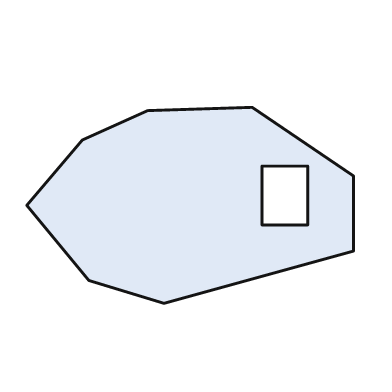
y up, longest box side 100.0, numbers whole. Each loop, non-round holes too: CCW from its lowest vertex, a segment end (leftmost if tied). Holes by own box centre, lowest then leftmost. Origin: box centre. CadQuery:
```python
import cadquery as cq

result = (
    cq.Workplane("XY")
    .moveTo(-8.0, -30.0)
    .lineTo(50.0, -14.0)
    .lineTo(50.0, 9.0)
    .lineTo(19.0, 30.0)
    .lineTo(-13.0, 29.0)
    .lineTo(-33.0, 20.0)
    .lineTo(-50.0, 0.0)
    .lineTo(-31.0, -23.0)
    .close()
    .moveTo(22.0, -6.0)
    .lineTo(36.0, -6.0)
    .lineTo(36.0, 12.0)
    .lineTo(22.0, 12.0)
    .close()
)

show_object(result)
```